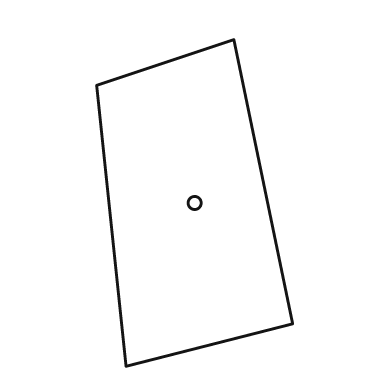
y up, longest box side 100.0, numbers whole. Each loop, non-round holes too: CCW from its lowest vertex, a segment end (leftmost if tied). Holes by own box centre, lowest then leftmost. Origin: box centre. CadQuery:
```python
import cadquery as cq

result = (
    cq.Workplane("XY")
    .moveTo(-21.0, -50.0)
    .lineTo(30.0, -37.0)
    .lineTo(12.0, 50.0)
    .lineTo(-30.0, 36.0)
    .close()
    .moveTo(0.0, 0.0)
    .circle(2.0)
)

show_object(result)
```